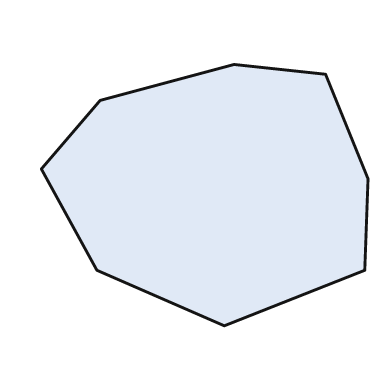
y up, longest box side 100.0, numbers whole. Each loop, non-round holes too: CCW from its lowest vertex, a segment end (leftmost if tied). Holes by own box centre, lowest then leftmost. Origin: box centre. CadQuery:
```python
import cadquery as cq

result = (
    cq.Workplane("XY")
    .moveTo(6.0, -40.0)
    .lineTo(49.0, -23.0)
    .lineTo(50.0, 5.0)
    .lineTo(37.0, 37.0)
    .lineTo(9.0, 40.0)
    .lineTo(-32.0, 29.0)
    .lineTo(-50.0, 8.0)
    .lineTo(-33.0, -23.0)
    .close()
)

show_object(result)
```